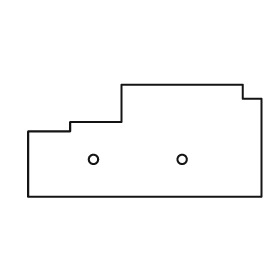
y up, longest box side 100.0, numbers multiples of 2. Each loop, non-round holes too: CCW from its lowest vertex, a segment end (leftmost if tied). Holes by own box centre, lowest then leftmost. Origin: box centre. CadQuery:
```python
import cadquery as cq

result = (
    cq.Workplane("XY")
    .moveTo(-50.0, -24.0)
    .lineTo(50.0, -24.0)
    .lineTo(50.0, 18.0)
    .lineTo(42.0, 18.0)
    .lineTo(42.0, 24.0)
    .lineTo(-10.0, 24.0)
    .lineTo(-10.0, 8.0)
    .lineTo(-32.0, 8.0)
    .lineTo(-32.0, 4.0)
    .lineTo(-50.0, 4.0)
    .close()
    .moveTo(-22.0, -8.0)
    .circle(2.0)
    .moveTo(16.0, -8.0)
    .circle(2.0)
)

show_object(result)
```